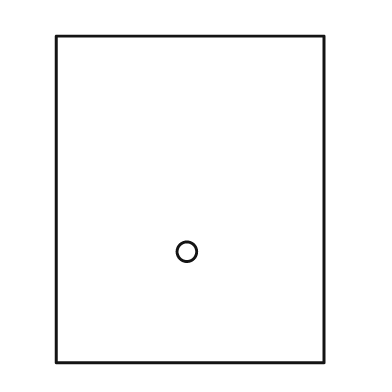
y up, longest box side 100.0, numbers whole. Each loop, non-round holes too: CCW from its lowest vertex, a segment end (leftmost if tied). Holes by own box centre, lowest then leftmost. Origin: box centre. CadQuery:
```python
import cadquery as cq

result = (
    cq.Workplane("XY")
    .moveTo(-41.0, -50.0)
    .lineTo(41.0, -50.0)
    .lineTo(41.0, 50.0)
    .lineTo(-41.0, 50.0)
    .close()
    .moveTo(-1.0, -16.0)
    .circle(3.0)
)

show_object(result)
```